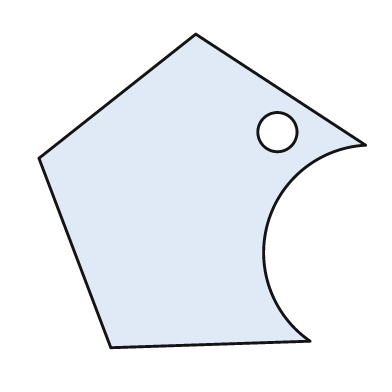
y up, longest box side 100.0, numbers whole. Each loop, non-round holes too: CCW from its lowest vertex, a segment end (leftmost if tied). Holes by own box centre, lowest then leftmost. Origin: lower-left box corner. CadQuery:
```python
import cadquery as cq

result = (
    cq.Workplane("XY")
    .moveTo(22.0, 0.0)
    .lineTo(83.0, 2.0)
    .threePointArc((70.0, 38.0), (100.0, 62.0))
    .lineTo(48.0, 96.0)
    .lineTo(0.0, 58.0)
    .close()
    .moveTo(73.0, 66.0)
    .circle(6.0)
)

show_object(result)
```